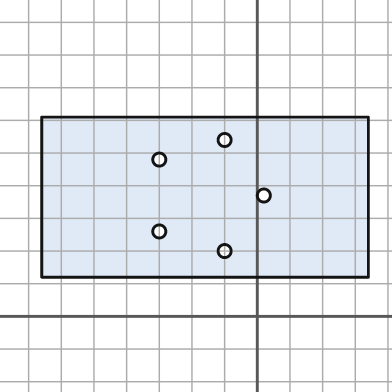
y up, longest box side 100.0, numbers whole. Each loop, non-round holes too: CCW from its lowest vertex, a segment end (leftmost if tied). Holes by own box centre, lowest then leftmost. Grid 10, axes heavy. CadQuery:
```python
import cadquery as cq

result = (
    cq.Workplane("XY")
    .moveTo(-66.0, 12.0)
    .lineTo(34.0, 12.0)
    .lineTo(34.0, 61.0)
    .lineTo(-66.0, 61.0)
    .close()
    .moveTo(-10.0, 20.0)
    .circle(2.0)
    .moveTo(-30.0, 26.0)
    .circle(2.0)
    .moveTo(2.0, 37.0)
    .circle(2.0)
    .moveTo(-30.0, 48.0)
    .circle(2.0)
    .moveTo(-10.0, 54.0)
    .circle(2.0)
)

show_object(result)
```